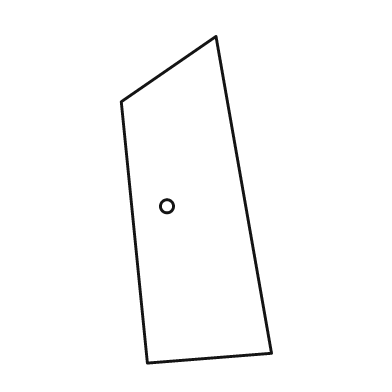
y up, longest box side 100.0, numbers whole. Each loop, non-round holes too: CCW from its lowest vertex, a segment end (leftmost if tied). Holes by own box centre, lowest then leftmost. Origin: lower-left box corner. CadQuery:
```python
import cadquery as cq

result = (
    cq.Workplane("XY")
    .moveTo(8.0, 0.0)
    .lineTo(46.0, 3.0)
    .lineTo(29.0, 100.0)
    .lineTo(0.0, 80.0)
    .close()
    .moveTo(14.0, 48.0)
    .circle(2.0)
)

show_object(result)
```